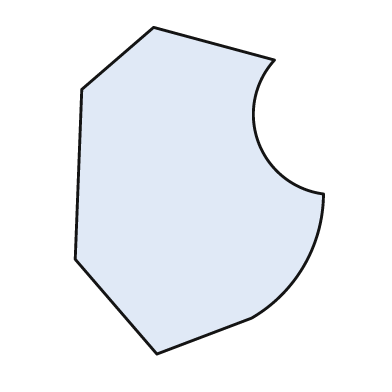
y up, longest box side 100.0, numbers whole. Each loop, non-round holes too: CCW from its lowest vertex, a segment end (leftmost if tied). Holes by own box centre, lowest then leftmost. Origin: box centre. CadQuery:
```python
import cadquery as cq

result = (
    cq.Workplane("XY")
    .moveTo(-13.0, -50.0)
    .lineTo(16.0, -39.0)
    .threePointArc((32.0, -23.0), (38.0, -1.0))
    .threePointArc((18.0, 15.0), (23.0, 40.0))
    .lineTo(-14.0, 50.0)
    .lineTo(-36.0, 31.0)
    .lineTo(-38.0, -21.0)
    .close()
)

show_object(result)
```